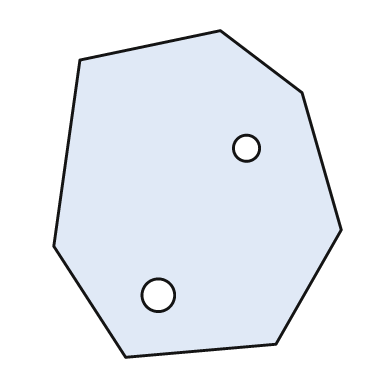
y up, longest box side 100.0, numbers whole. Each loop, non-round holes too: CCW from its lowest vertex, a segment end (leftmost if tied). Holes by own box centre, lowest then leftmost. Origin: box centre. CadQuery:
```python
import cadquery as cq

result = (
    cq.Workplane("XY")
    .moveTo(-22.0, -50.0)
    .lineTo(24.0, -46.0)
    .lineTo(44.0, -11.0)
    .lineTo(32.0, 31.0)
    .lineTo(7.0, 50.0)
    .lineTo(-36.0, 41.0)
    .lineTo(-44.0, -16.0)
    .close()
    .moveTo(-12.0, -31.0)
    .circle(5.0)
    .moveTo(15.0, 14.0)
    .circle(4.0)
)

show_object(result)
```